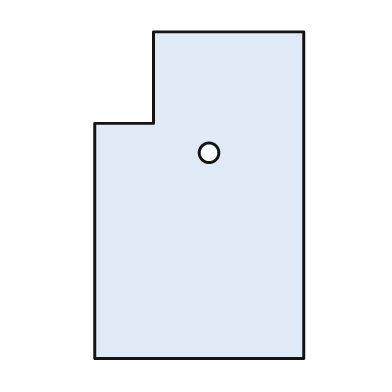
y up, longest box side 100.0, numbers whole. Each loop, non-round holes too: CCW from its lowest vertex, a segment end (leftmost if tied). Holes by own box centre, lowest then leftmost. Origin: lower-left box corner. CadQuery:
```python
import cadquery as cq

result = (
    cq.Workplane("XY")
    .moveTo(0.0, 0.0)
    .lineTo(64.0, 0.0)
    .lineTo(64.0, 100.0)
    .lineTo(18.0, 100.0)
    .lineTo(18.0, 72.0)
    .lineTo(0.0, 72.0)
    .close()
    .moveTo(35.0, 63.0)
    .circle(3.0)
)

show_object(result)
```